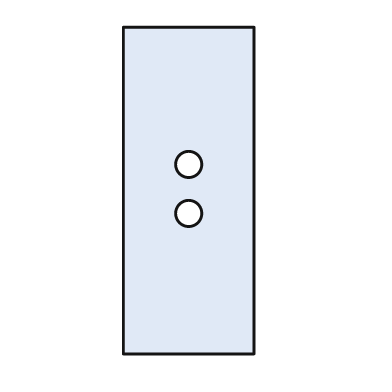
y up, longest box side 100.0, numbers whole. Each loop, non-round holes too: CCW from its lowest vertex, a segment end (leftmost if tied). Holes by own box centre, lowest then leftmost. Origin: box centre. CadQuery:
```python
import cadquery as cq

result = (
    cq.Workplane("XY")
    .moveTo(-20.0, -50.0)
    .lineTo(20.0, -50.0)
    .lineTo(20.0, 50.0)
    .lineTo(-20.0, 50.0)
    .close()
    .moveTo(0.0, -7.0)
    .circle(4.0)
    .moveTo(0.0, 8.0)
    .circle(4.0)
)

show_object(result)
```